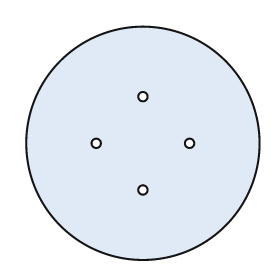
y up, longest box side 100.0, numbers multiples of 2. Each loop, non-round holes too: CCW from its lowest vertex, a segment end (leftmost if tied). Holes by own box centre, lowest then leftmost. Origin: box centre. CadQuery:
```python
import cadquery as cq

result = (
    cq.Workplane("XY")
    .moveTo(0.0, 0.0)
    .circle(50.0)
    .moveTo(0.0, -20.0)
    .circle(2.0)
    .moveTo(-20.0, 0.0)
    .circle(2.0)
    .moveTo(20.0, 0.0)
    .circle(2.0)
    .moveTo(0.0, 20.0)
    .circle(2.0)
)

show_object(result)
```